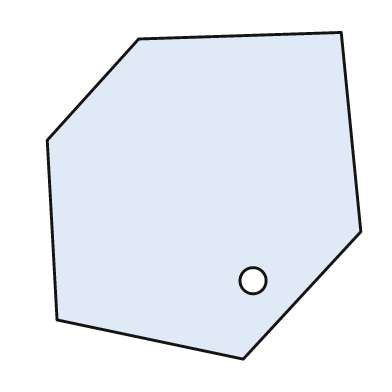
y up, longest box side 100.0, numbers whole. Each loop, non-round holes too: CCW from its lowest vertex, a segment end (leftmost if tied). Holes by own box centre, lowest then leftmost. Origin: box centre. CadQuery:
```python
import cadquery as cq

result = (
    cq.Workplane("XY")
    .moveTo(12.0, -50.0)
    .lineTo(48.0, -11.0)
    .lineTo(42.0, 50.0)
    .lineTo(-20.0, 48.0)
    .lineTo(-48.0, 17.0)
    .lineTo(-45.0, -38.0)
    .close()
    .moveTo(15.0, -26.0)
    .circle(4.0)
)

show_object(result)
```